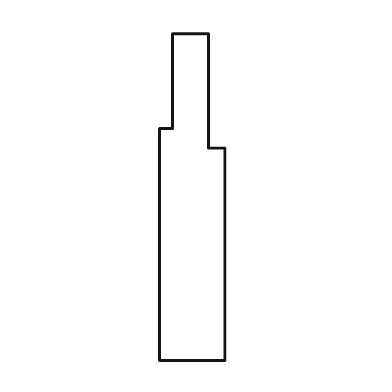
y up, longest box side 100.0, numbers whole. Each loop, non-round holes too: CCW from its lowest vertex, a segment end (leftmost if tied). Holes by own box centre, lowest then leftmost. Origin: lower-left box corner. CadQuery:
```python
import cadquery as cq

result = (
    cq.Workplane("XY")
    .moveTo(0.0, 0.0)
    .lineTo(20.0, 0.0)
    .lineTo(20.0, 65.0)
    .lineTo(15.0, 65.0)
    .lineTo(15.0, 100.0)
    .lineTo(4.0, 100.0)
    .lineTo(4.0, 71.0)
    .lineTo(0.0, 71.0)
    .close()
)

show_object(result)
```